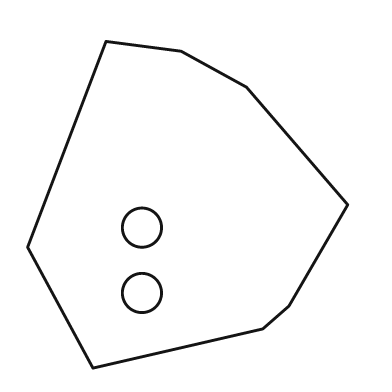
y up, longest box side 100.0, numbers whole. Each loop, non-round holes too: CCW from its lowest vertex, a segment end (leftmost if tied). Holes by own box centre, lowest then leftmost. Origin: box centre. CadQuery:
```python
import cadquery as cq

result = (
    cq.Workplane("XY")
    .moveTo(-29.0, -50.0)
    .lineTo(23.0, -38.0)
    .lineTo(31.0, -31.0)
    .lineTo(49.0, 0.0)
    .lineTo(18.0, 36.0)
    .lineTo(-2.0, 47.0)
    .lineTo(-25.0, 50.0)
    .lineTo(-49.0, -13.0)
    .close()
    .moveTo(-14.0, -27.0)
    .circle(6.0)
    .moveTo(-14.0, -7.0)
    .circle(6.0)
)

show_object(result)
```